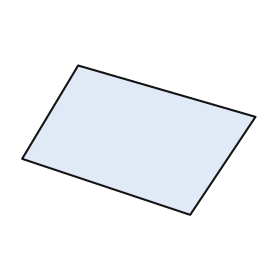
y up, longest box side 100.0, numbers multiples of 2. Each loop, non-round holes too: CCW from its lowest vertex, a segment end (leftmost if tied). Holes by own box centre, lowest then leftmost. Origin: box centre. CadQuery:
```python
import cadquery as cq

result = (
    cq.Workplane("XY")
    .moveTo(22.0, -32.0)
    .lineTo(50.0, 10.0)
    .lineTo(-26.0, 32.0)
    .lineTo(-50.0, -8.0)
    .close()
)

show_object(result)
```